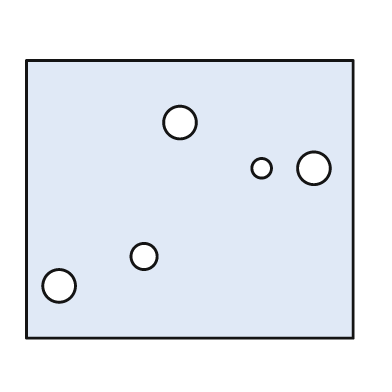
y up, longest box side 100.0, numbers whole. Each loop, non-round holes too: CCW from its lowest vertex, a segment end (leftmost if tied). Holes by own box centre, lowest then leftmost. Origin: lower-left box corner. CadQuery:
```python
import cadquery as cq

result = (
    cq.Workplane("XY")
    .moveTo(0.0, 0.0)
    .lineTo(100.0, 0.0)
    .lineTo(100.0, 85.0)
    .lineTo(0.0, 85.0)
    .close()
    .moveTo(10.0, 16.0)
    .circle(5.0)
    .moveTo(36.0, 25.0)
    .circle(4.0)
    .moveTo(72.0, 52.0)
    .circle(3.0)
    .moveTo(88.0, 52.0)
    .circle(5.0)
    .moveTo(47.0, 66.0)
    .circle(5.0)
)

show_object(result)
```